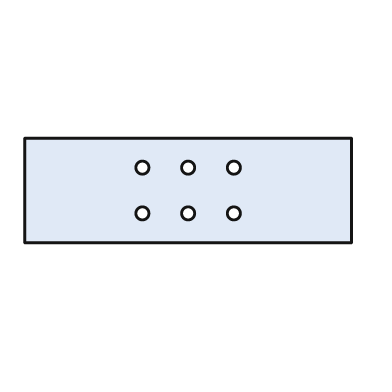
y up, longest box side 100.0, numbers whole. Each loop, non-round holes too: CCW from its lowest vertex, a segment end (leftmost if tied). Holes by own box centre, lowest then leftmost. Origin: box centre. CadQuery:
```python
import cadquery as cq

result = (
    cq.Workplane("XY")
    .moveTo(-50.0, -16.0)
    .lineTo(50.0, -16.0)
    .lineTo(50.0, 16.0)
    .lineTo(-50.0, 16.0)
    .close()
    .moveTo(-14.0, -7.0)
    .circle(2.0)
    .moveTo(0.0, -7.0)
    .circle(2.0)
    .moveTo(14.0, -7.0)
    .circle(2.0)
    .moveTo(-14.0, 7.0)
    .circle(2.0)
    .moveTo(0.0, 7.0)
    .circle(2.0)
    .moveTo(14.0, 7.0)
    .circle(2.0)
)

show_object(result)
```